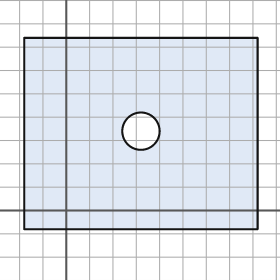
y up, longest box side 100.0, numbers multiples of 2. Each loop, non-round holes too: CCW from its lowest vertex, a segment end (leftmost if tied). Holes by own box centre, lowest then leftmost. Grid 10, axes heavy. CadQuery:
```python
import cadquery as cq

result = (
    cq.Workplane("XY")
    .moveTo(-18.0, -8.0)
    .lineTo(82.0, -8.0)
    .lineTo(82.0, 74.0)
    .lineTo(-18.0, 74.0)
    .close()
    .moveTo(32.0, 34.0)
    .circle(8.0)
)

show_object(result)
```